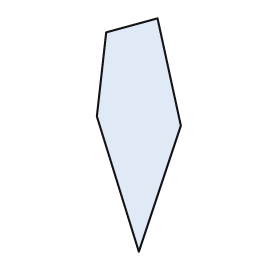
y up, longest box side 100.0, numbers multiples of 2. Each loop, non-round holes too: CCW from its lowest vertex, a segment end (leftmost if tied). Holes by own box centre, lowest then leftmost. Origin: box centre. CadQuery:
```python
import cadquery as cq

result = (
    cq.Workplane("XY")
    .moveTo(0.0, -50.0)
    .lineTo(18.0, 4.0)
    .lineTo(8.0, 50.0)
    .lineTo(-14.0, 44.0)
    .lineTo(-18.0, 8.0)
    .close()
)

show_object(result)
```